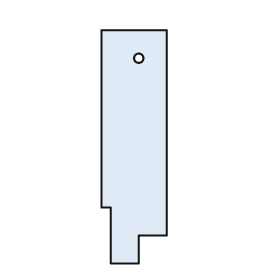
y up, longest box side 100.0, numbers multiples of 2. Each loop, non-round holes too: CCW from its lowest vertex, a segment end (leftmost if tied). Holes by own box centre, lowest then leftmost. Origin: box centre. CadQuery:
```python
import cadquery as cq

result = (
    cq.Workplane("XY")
    .moveTo(-10.0, -50.0)
    .lineTo(2.0, -50.0)
    .lineTo(2.0, -38.0)
    .lineTo(14.0, -38.0)
    .lineTo(14.0, 50.0)
    .lineTo(-14.0, 50.0)
    .lineTo(-14.0, -26.0)
    .lineTo(-10.0, -26.0)
    .close()
    .moveTo(2.0, 38.0)
    .circle(2.0)
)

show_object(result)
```